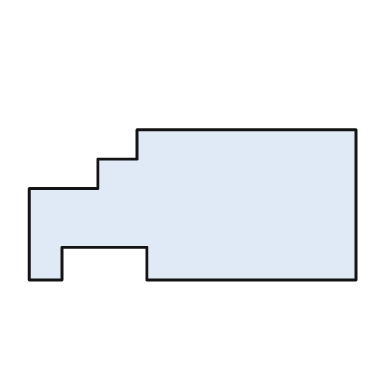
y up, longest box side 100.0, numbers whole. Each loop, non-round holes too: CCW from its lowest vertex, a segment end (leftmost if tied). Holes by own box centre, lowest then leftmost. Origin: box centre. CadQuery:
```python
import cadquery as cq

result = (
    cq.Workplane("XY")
    .moveTo(-50.0, -23.0)
    .lineTo(-40.0, -23.0)
    .lineTo(-40.0, -13.0)
    .lineTo(-14.0, -13.0)
    .lineTo(-14.0, -23.0)
    .lineTo(50.0, -23.0)
    .lineTo(50.0, 23.0)
    .lineTo(-17.0, 23.0)
    .lineTo(-17.0, 14.0)
    .lineTo(-29.0, 14.0)
    .lineTo(-29.0, 5.0)
    .lineTo(-50.0, 5.0)
    .close()
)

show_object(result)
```